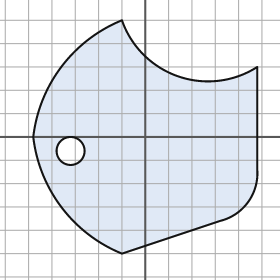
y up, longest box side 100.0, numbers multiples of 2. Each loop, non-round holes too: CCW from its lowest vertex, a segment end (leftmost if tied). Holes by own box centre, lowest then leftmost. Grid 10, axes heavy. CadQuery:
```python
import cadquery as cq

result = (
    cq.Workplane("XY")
    .moveTo(-10.0, -50.0)
    .lineTo(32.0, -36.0)
    .threePointArc((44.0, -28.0), (48.0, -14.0))
    .lineTo(48.0, 30.0)
    .threePointArc((14.0, 26.0), (-10.0, 50.0))
    .threePointArc((-36.0, 30.0), (-48.0, 0.0))
    .threePointArc((-36.0, -30.0), (-10.0, -50.0))
    .close()
    .moveTo(-32.0, -6.0)
    .circle(6.0)
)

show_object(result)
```